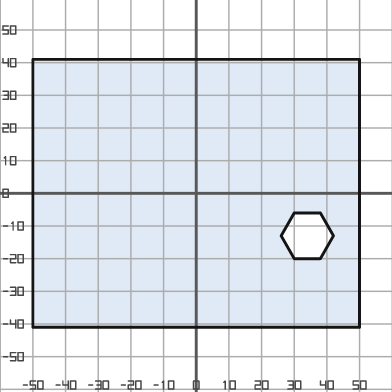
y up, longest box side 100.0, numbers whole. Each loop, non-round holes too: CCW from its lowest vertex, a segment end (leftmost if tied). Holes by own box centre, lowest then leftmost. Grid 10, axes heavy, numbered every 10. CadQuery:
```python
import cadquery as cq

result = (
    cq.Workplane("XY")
    .moveTo(-50.0, -41.0)
    .lineTo(50.0, -41.0)
    .lineTo(50.0, 41.0)
    .lineTo(-50.0, 41.0)
    .close()
    .moveTo(30.0, -20.0)
    .lineTo(38.0, -20.0)
    .lineTo(42.0, -13.0)
    .lineTo(38.0, -6.0)
    .lineTo(30.0, -6.0)
    .lineTo(26.0, -13.0)
    .close()
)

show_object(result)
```